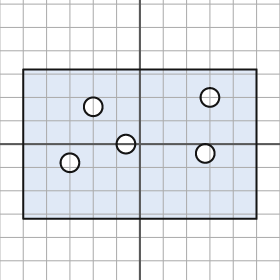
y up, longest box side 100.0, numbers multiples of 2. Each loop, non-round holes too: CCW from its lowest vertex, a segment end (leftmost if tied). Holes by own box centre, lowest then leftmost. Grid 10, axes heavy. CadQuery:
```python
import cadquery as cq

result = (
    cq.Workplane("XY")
    .moveTo(-50.0, -32.0)
    .lineTo(50.0, -32.0)
    .lineTo(50.0, 32.0)
    .lineTo(-50.0, 32.0)
    .close()
    .moveTo(-30.0, -8.0)
    .circle(4.0)
    .moveTo(28.0, -4.0)
    .circle(4.0)
    .moveTo(-6.0, 0.0)
    .circle(4.0)
    .moveTo(-20.0, 16.0)
    .circle(4.0)
    .moveTo(30.0, 20.0)
    .circle(4.0)
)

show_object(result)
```